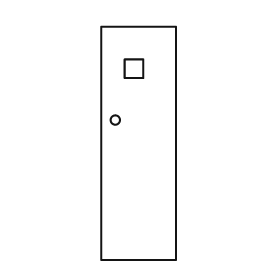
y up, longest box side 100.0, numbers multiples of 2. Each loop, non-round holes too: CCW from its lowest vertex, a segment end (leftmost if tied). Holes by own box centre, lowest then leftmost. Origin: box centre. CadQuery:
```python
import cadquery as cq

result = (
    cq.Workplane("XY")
    .moveTo(-16.0, -50.0)
    .lineTo(16.0, -50.0)
    .lineTo(16.0, 50.0)
    .lineTo(-16.0, 50.0)
    .close()
    .moveTo(-10.0, 10.0)
    .circle(2.0)
    .moveTo(-6.0, 28.0)
    .lineTo(2.0, 28.0)
    .lineTo(2.0, 36.0)
    .lineTo(-6.0, 36.0)
    .close()
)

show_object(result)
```